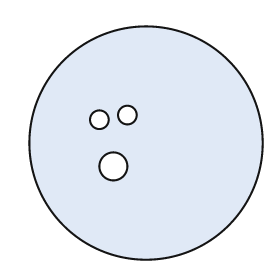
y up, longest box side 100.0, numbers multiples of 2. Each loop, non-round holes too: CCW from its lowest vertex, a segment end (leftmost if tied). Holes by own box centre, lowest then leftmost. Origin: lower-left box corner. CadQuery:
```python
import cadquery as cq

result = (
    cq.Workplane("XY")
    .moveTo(50.0, 50.0)
    .circle(50.0)
    .moveTo(36.0, 40.0)
    .circle(6.0)
    .moveTo(30.0, 60.0)
    .circle(4.0)
    .moveTo(42.0, 62.0)
    .circle(4.0)
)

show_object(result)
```